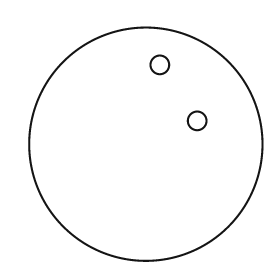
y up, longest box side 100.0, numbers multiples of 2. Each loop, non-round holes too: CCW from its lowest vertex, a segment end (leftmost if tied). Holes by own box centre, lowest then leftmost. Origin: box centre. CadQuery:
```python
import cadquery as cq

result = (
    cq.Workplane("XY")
    .moveTo(0.0, 0.0)
    .circle(50.0)
    .moveTo(22.0, 10.0)
    .circle(4.0)
    .moveTo(6.0, 34.0)
    .circle(4.0)
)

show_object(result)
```